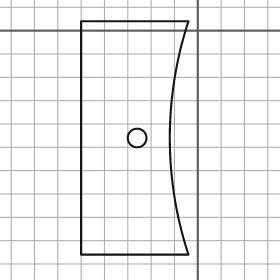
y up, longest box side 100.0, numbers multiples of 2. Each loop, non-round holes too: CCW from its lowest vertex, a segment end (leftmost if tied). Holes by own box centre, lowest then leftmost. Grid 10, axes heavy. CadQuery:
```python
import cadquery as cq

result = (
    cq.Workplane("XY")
    .moveTo(-50.0, -96.0)
    .lineTo(-4.0, -96.0)
    .threePointArc((-12.0, -46.0), (-4.0, 4.0))
    .lineTo(-50.0, 4.0)
    .close()
    .moveTo(-26.0, -46.0)
    .circle(4.0)
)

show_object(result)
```